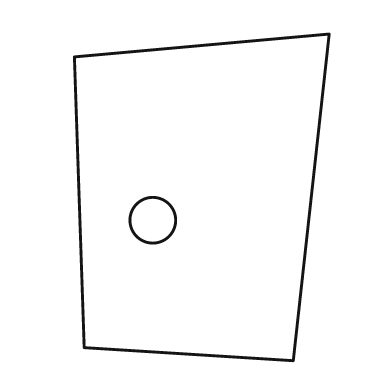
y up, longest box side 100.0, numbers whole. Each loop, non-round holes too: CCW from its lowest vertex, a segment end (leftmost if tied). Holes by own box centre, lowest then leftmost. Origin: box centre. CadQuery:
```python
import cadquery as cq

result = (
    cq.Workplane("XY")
    .moveTo(28.0, -50.0)
    .lineTo(39.0, 50.0)
    .lineTo(-39.0, 43.0)
    .lineTo(-36.0, -46.0)
    .close()
    .moveTo(-15.0, -7.0)
    .circle(7.0)
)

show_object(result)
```